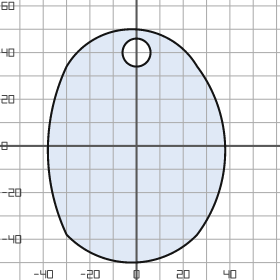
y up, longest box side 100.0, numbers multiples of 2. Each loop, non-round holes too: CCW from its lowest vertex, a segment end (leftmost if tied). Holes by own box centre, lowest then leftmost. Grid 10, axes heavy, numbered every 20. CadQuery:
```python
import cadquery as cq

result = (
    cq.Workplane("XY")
    .moveTo(-30.0, -38.0)
    .threePointArc((-2.0, -50.0), (26.0, -38.0))
    .threePointArc((38.0, -2.0), (26.0, 34.0))
    .threePointArc((-2.0, 50.0), (-30.0, 34.0))
    .threePointArc((-38.0, -2.0), (-30.0, -38.0))
    .close()
    .moveTo(0.0, 40.0)
    .circle(6.0)
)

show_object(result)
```